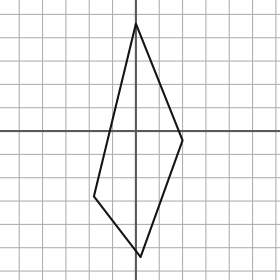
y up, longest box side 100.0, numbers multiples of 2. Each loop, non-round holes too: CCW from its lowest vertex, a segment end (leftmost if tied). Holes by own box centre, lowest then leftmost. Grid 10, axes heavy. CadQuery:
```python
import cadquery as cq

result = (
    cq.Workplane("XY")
    .moveTo(2.0, -54.0)
    .lineTo(20.0, -4.0)
    .lineTo(0.0, 46.0)
    .lineTo(-18.0, -28.0)
    .close()
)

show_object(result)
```